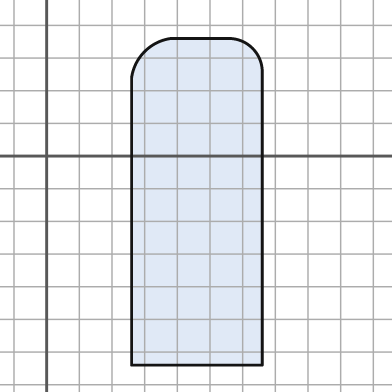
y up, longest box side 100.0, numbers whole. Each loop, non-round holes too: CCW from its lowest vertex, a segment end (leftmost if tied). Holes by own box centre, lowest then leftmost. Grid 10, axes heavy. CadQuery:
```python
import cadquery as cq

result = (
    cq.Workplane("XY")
    .moveTo(26.0, -64.0)
    .lineTo(66.0, -64.0)
    .lineTo(66.0, 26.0)
    .threePointArc((63.0, 33.0), (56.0, 36.0))
    .lineTo(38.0, 36.0)
    .threePointArc((30.0, 32.0), (26.0, 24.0))
    .close()
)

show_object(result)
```